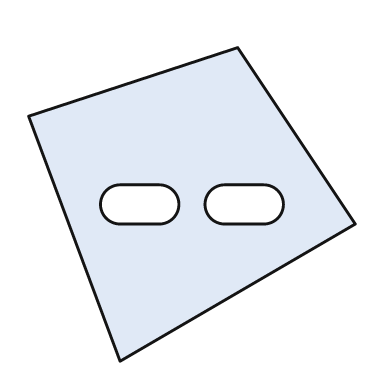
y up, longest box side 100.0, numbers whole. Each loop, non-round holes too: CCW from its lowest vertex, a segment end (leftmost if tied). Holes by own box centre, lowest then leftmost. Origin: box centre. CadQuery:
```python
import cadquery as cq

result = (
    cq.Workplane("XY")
    .moveTo(-22.0, -48.0)
    .lineTo(50.0, -6.0)
    .lineTo(14.0, 48.0)
    .lineTo(-50.0, 27.0)
    .close()
    .moveTo(-22.0, -6.0)
    .lineTo(-10.0, -6.0)
    .threePointArc((-4.0, 0.0), (-10.0, 6.0))
    .lineTo(-22.0, 6.0)
    .threePointArc((-28.0, 0.0), (-22.0, -6.0))
    .close()
    .moveTo(10.0, -6.0)
    .lineTo(22.0, -6.0)
    .threePointArc((28.0, 0.0), (22.0, 6.0))
    .lineTo(10.0, 6.0)
    .threePointArc((4.0, 0.0), (10.0, -6.0))
    .close()
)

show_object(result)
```